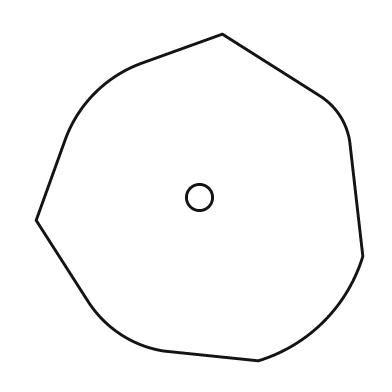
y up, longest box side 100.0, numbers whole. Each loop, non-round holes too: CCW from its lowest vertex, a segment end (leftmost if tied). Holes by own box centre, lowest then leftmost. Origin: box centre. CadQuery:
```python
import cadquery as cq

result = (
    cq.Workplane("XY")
    .moveTo(18.0, -50.0)
    .threePointArc((38.0, -38.0), (50.0, -18.0))
    .lineTo(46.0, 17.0)
    .threePointArc((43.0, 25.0), (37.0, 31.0))
    .lineTo(7.0, 50.0)
    .lineTo(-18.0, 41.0)
    .threePointArc((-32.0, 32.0), (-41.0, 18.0))
    .lineTo(-50.0, -7.0)
    .lineTo(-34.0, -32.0)
    .threePointArc((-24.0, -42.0), (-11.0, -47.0))
    .close()
    .moveTo(0.0, 0.0)
    .circle(4.0)
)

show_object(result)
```